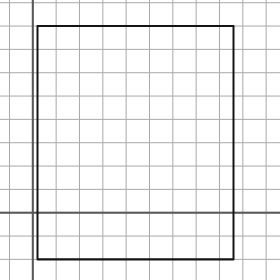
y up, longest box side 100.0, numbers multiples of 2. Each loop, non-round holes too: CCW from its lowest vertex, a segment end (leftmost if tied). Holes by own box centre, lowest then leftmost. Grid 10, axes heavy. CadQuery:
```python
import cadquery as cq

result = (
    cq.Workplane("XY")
    .moveTo(2.0, -20.0)
    .lineTo(86.0, -20.0)
    .lineTo(86.0, 80.0)
    .lineTo(2.0, 80.0)
    .close()
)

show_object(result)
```